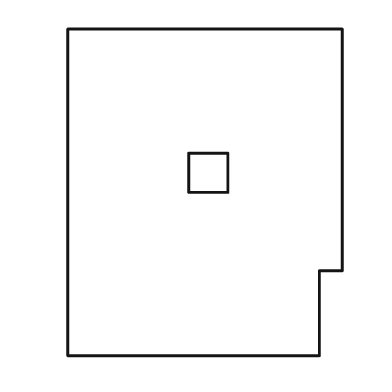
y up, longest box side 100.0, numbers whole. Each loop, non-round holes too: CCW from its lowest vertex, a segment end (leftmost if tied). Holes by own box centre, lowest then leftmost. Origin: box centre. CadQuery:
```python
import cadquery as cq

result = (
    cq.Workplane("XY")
    .moveTo(-42.0, -50.0)
    .lineTo(35.0, -50.0)
    .lineTo(35.0, -24.0)
    .lineTo(42.0, -24.0)
    .lineTo(42.0, 50.0)
    .lineTo(-42.0, 50.0)
    .close()
    .moveTo(-5.0, 0.0)
    .lineTo(7.0, 0.0)
    .lineTo(7.0, 12.0)
    .lineTo(-5.0, 12.0)
    .close()
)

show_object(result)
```